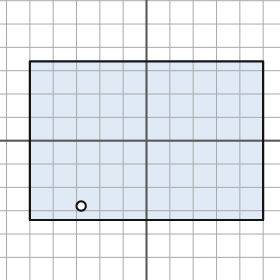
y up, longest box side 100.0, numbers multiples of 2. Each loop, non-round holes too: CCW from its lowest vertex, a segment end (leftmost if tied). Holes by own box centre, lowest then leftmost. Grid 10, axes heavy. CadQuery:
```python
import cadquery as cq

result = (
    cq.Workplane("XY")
    .moveTo(-50.0, -34.0)
    .lineTo(50.0, -34.0)
    .lineTo(50.0, 34.0)
    .lineTo(-50.0, 34.0)
    .close()
    .moveTo(-28.0, -28.0)
    .circle(2.0)
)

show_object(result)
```